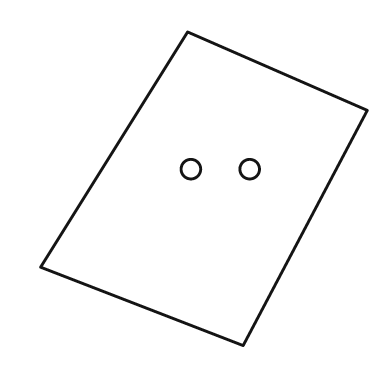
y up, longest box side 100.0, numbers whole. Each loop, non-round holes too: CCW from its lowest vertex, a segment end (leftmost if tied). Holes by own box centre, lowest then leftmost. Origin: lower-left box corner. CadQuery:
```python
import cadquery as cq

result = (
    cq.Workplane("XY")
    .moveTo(62.0, 0.0)
    .lineTo(100.0, 72.0)
    .lineTo(45.0, 96.0)
    .lineTo(0.0, 24.0)
    .close()
    .moveTo(46.0, 54.0)
    .circle(3.0)
    .moveTo(64.0, 54.0)
    .circle(3.0)
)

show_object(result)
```